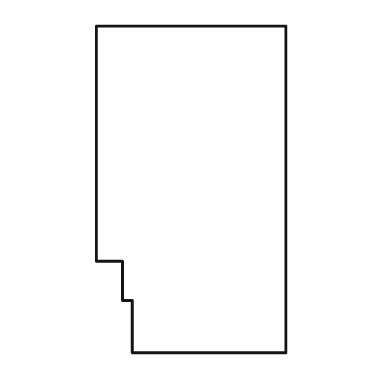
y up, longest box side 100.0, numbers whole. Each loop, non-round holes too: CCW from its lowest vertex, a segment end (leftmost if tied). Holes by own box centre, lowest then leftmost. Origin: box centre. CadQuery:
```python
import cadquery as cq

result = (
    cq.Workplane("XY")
    .moveTo(-18.0, -50.0)
    .lineTo(29.0, -50.0)
    .lineTo(29.0, 50.0)
    .lineTo(-29.0, 50.0)
    .lineTo(-29.0, -22.0)
    .lineTo(-21.0, -22.0)
    .lineTo(-21.0, -34.0)
    .lineTo(-18.0, -34.0)
    .close()
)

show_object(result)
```